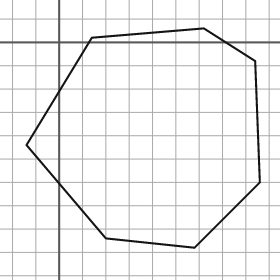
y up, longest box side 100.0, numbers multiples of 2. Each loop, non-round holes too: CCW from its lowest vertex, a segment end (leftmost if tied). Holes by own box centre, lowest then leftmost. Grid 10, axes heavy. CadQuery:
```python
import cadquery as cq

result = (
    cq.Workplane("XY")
    .moveTo(58.0, -88.0)
    .lineTo(86.0, -60.0)
    .lineTo(84.0, -8.0)
    .lineTo(62.0, 6.0)
    .lineTo(14.0, 2.0)
    .lineTo(-14.0, -44.0)
    .lineTo(20.0, -84.0)
    .close()
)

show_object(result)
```